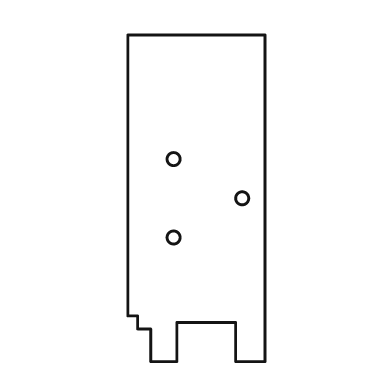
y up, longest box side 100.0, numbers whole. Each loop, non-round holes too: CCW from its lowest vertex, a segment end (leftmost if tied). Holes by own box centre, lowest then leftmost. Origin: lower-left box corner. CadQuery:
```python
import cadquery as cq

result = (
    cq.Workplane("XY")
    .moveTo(7.0, 0.0)
    .lineTo(15.0, 0.0)
    .lineTo(15.0, 12.0)
    .lineTo(33.0, 12.0)
    .lineTo(33.0, 0.0)
    .lineTo(42.0, 0.0)
    .lineTo(42.0, 100.0)
    .lineTo(0.0, 100.0)
    .lineTo(0.0, 14.0)
    .lineTo(3.0, 14.0)
    .lineTo(3.0, 10.0)
    .lineTo(7.0, 10.0)
    .close()
    .moveTo(14.0, 38.0)
    .circle(2.0)
    .moveTo(35.0, 50.0)
    .circle(2.0)
    .moveTo(14.0, 62.0)
    .circle(2.0)
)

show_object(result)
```